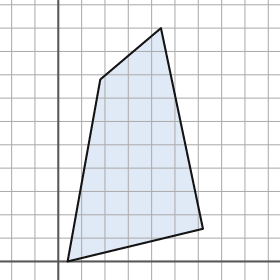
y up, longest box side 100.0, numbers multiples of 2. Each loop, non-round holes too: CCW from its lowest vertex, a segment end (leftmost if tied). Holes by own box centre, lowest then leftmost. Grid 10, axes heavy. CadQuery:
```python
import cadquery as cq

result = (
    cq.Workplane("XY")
    .moveTo(4.0, 0.0)
    .lineTo(62.0, 14.0)
    .lineTo(44.0, 100.0)
    .lineTo(18.0, 78.0)
    .close()
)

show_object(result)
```